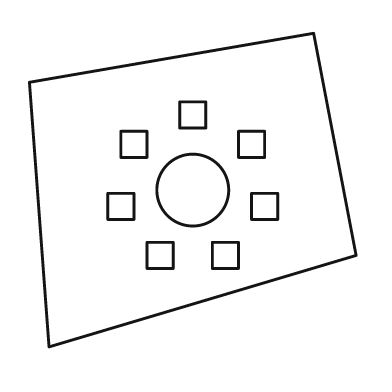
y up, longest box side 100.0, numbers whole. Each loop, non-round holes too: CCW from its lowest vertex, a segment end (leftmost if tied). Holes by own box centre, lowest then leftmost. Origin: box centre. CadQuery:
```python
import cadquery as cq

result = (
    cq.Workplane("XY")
    .moveTo(-44.0, -48.0)
    .lineTo(50.0, -20.0)
    .lineTo(37.0, 48.0)
    .lineTo(-50.0, 33.0)
    .close()
    .moveTo(-14.0, -24.0)
    .lineTo(-6.0, -24.0)
    .lineTo(-6.0, -16.0)
    .lineTo(-14.0, -16.0)
    .close()
    .moveTo(6.0, -24.0)
    .lineTo(14.0, -24.0)
    .lineTo(14.0, -16.0)
    .lineTo(6.0, -16.0)
    .close()
    .moveTo(-26.0, -9.0)
    .lineTo(-18.0, -9.0)
    .lineTo(-18.0, -1.0)
    .lineTo(-26.0, -1.0)
    .close()
    .moveTo(18.0, -9.0)
    .lineTo(26.0, -9.0)
    .lineTo(26.0, -1.0)
    .lineTo(18.0, -1.0)
    .close()
    .moveTo(0.0, 0.0)
    .circle(11.0)
    .moveTo(-22.0, 10.0)
    .lineTo(-14.0, 10.0)
    .lineTo(-14.0, 18.0)
    .lineTo(-22.0, 18.0)
    .close()
    .moveTo(14.0, 10.0)
    .lineTo(22.0, 10.0)
    .lineTo(22.0, 18.0)
    .lineTo(14.0, 18.0)
    .close()
    .moveTo(-4.0, 19.0)
    .lineTo(4.0, 19.0)
    .lineTo(4.0, 27.0)
    .lineTo(-4.0, 27.0)
    .close()
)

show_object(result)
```